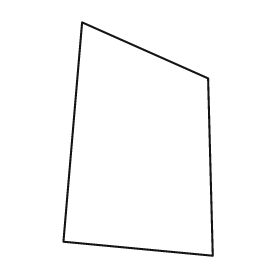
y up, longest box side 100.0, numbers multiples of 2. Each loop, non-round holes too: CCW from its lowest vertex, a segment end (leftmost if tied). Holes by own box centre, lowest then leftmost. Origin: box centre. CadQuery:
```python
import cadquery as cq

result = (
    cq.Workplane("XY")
    .moveTo(32.0, -50.0)
    .lineTo(30.0, 26.0)
    .lineTo(-24.0, 50.0)
    .lineTo(-32.0, -44.0)
    .close()
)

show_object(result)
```